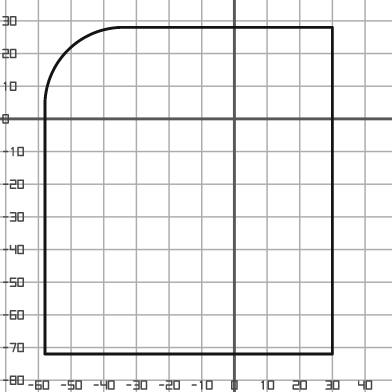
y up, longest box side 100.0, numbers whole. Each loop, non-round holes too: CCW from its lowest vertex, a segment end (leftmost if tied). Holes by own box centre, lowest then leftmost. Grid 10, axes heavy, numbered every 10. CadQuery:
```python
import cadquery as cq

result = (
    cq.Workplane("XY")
    .moveTo(-58.0, -72.0)
    .lineTo(30.0, -72.0)
    .lineTo(30.0, 28.0)
    .lineTo(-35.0, 28.0)
    .threePointArc((-51.0, 21.0), (-58.0, 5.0))
    .close()
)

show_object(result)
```